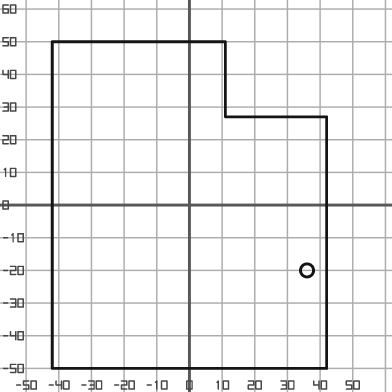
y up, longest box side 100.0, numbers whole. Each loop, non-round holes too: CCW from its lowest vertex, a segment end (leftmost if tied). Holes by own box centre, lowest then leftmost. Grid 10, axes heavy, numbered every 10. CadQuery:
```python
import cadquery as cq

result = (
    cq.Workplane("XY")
    .moveTo(-42.0, -50.0)
    .lineTo(42.0, -50.0)
    .lineTo(42.0, 27.0)
    .lineTo(11.0, 27.0)
    .lineTo(11.0, 50.0)
    .lineTo(-42.0, 50.0)
    .close()
    .moveTo(36.0, -20.0)
    .circle(2.0)
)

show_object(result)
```